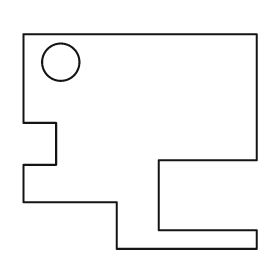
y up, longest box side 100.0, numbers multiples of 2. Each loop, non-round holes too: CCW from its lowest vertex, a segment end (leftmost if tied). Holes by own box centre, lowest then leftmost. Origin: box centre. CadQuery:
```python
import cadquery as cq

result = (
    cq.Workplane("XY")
    .moveTo(-10.0, -46.0)
    .lineTo(50.0, -46.0)
    .lineTo(50.0, -38.0)
    .lineTo(8.0, -38.0)
    .lineTo(8.0, -8.0)
    .lineTo(50.0, -8.0)
    .lineTo(50.0, 46.0)
    .lineTo(-50.0, 46.0)
    .lineTo(-50.0, 8.0)
    .lineTo(-36.0, 8.0)
    .lineTo(-36.0, -10.0)
    .lineTo(-50.0, -10.0)
    .lineTo(-50.0, -26.0)
    .lineTo(-10.0, -26.0)
    .close()
    .moveTo(-34.0, 34.0)
    .circle(8.0)
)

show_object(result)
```